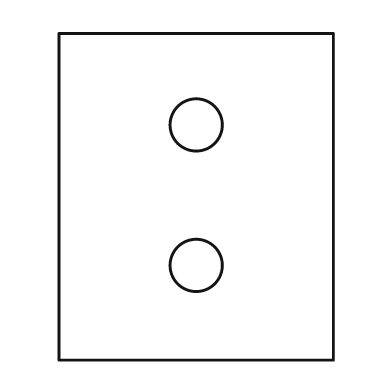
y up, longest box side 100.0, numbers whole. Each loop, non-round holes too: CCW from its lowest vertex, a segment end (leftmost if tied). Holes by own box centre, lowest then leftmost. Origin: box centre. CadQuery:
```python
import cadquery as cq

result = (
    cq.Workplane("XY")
    .moveTo(-42.0, -50.0)
    .lineTo(42.0, -50.0)
    .lineTo(42.0, 50.0)
    .lineTo(-42.0, 50.0)
    .close()
    .moveTo(0.0, -21.0)
    .circle(8.0)
    .moveTo(0.0, 22.0)
    .circle(8.0)
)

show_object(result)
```